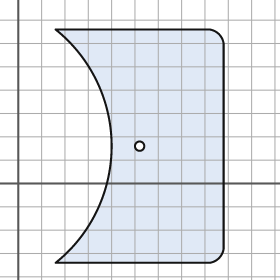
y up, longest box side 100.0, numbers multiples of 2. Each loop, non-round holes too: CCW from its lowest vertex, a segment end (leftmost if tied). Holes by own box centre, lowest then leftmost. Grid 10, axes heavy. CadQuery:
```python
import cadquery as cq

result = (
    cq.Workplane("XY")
    .moveTo(16.0, -34.0)
    .lineTo(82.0, -34.0)
    .threePointArc((86.0, -32.0), (88.0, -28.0))
    .lineTo(88.0, 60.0)
    .threePointArc((86.0, 64.0), (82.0, 66.0))
    .lineTo(16.0, 66.0)
    .threePointArc((40.0, 16.0), (16.0, -34.0))
    .close()
    .moveTo(52.0, 16.0)
    .circle(2.0)
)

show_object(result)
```